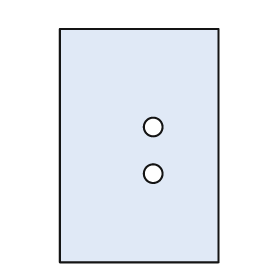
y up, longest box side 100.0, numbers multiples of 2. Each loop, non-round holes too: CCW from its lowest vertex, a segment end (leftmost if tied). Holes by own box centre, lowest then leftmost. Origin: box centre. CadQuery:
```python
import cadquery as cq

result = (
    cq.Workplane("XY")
    .moveTo(-34.0, -50.0)
    .lineTo(34.0, -50.0)
    .lineTo(34.0, 50.0)
    .lineTo(-34.0, 50.0)
    .close()
    .moveTo(6.0, -12.0)
    .circle(4.0)
    .moveTo(6.0, 8.0)
    .circle(4.0)
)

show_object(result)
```